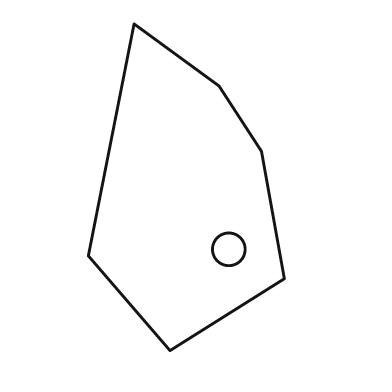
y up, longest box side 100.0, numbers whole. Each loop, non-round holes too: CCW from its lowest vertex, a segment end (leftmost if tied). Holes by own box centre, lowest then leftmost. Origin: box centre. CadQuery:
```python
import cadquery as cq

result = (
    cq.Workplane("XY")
    .moveTo(-5.0, -50.0)
    .lineTo(30.0, -28.0)
    .lineTo(23.0, 11.0)
    .lineTo(10.0, 31.0)
    .lineTo(-16.0, 50.0)
    .lineTo(-30.0, -21.0)
    .close()
    .moveTo(13.0, -19.0)
    .circle(5.0)
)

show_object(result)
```